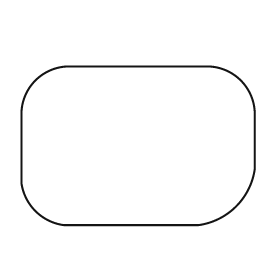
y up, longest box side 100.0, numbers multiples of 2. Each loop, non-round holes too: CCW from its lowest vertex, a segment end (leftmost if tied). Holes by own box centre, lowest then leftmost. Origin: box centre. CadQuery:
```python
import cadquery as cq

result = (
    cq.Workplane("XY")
    .moveTo(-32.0, -34.0)
    .lineTo(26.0, -34.0)
    .threePointArc((42.0, -26.0), (50.0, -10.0))
    .lineTo(50.0, 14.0)
    .threePointArc((44.0, 28.0), (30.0, 34.0))
    .lineTo(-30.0, 34.0)
    .threePointArc((-44.0, 28.0), (-50.0, 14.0))
    .lineTo(-50.0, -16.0)
    .threePointArc((-44.0, -28.0), (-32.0, -34.0))
    .close()
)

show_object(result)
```